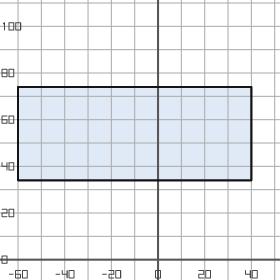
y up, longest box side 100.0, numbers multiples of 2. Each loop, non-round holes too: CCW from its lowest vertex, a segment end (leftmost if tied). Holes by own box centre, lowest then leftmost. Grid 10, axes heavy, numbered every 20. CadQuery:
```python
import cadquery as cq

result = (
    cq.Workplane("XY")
    .moveTo(-60.0, 34.0)
    .lineTo(40.0, 34.0)
    .lineTo(40.0, 74.0)
    .lineTo(-60.0, 74.0)
    .close()
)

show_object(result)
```